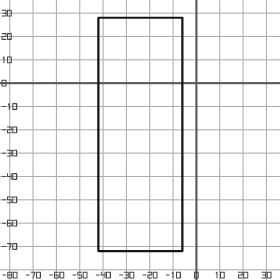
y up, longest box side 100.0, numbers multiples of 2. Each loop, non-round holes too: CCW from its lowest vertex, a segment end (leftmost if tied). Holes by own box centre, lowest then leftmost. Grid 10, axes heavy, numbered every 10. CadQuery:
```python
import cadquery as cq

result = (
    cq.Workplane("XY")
    .moveTo(-42.0, -72.0)
    .lineTo(-6.0, -72.0)
    .lineTo(-6.0, 28.0)
    .lineTo(-42.0, 28.0)
    .close()
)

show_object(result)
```